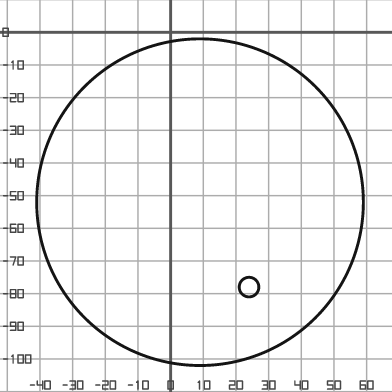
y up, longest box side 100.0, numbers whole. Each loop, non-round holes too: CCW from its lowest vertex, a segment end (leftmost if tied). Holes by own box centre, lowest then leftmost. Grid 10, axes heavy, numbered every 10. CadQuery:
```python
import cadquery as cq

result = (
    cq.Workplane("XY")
    .moveTo(9.0, -52.0)
    .circle(50.0)
    .moveTo(24.0, -78.0)
    .circle(3.0)
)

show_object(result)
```